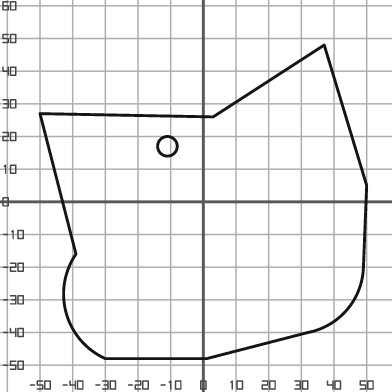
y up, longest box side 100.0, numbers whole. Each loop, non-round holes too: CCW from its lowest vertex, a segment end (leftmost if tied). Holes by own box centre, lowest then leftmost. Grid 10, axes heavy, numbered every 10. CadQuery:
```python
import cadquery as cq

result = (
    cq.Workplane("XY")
    .moveTo(-30.0, -48.0)
    .lineTo(1.0, -48.0)
    .lineTo(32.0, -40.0)
    .threePointArc((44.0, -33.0), (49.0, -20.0))
    .lineTo(50.0, 5.0)
    .lineTo(37.0, 48.0)
    .lineTo(3.0, 26.0)
    .lineTo(-50.0, 27.0)
    .lineTo(-39.0, -16.0)
    .threePointArc((-42.0, -34.0), (-30.0, -48.0))
    .close()
    .moveTo(-11.0, 17.0)
    .circle(3.0)
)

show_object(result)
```